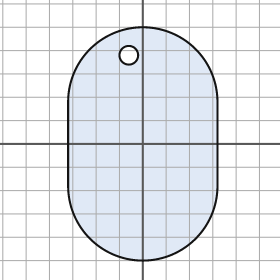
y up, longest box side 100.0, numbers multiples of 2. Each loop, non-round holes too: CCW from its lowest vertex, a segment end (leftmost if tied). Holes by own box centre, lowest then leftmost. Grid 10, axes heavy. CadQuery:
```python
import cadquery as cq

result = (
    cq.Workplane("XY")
    .moveTo(-32.0, -18.0)
    .threePointArc((0.0, -50.0), (32.0, -18.0))
    .lineTo(32.0, 18.0)
    .threePointArc((0.0, 50.0), (-32.0, 18.0))
    .close()
    .moveTo(-6.0, 38.0)
    .circle(4.0)
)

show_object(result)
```